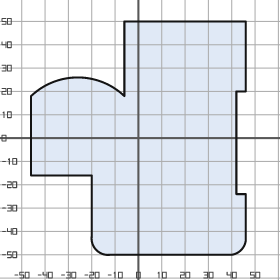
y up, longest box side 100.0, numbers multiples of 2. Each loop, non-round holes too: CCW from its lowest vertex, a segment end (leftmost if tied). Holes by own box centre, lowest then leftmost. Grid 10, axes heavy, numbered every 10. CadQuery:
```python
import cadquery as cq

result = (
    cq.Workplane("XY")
    .moveTo(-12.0, -50.0)
    .lineTo(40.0, -50.0)
    .threePointArc((44.0, -48.0), (46.0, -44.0))
    .lineTo(46.0, -24.0)
    .lineTo(42.0, -24.0)
    .lineTo(42.0, 20.0)
    .lineTo(46.0, 20.0)
    .lineTo(46.0, 50.0)
    .lineTo(-6.0, 50.0)
    .lineTo(-6.0, 18.0)
    .threePointArc((-26.0, 26.0), (-46.0, 18.0))
    .lineTo(-46.0, -16.0)
    .lineTo(-20.0, -16.0)
    .lineTo(-20.0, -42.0)
    .threePointArc((-18.0, -48.0), (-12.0, -50.0))
    .close()
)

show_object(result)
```